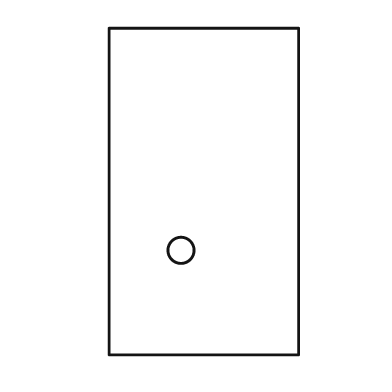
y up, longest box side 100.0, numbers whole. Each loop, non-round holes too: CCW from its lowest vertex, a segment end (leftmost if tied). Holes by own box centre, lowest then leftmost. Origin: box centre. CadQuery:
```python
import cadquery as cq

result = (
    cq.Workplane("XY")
    .moveTo(-29.0, -50.0)
    .lineTo(29.0, -50.0)
    .lineTo(29.0, 50.0)
    .lineTo(-29.0, 50.0)
    .close()
    .moveTo(-7.0, -18.0)
    .circle(4.0)
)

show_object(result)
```